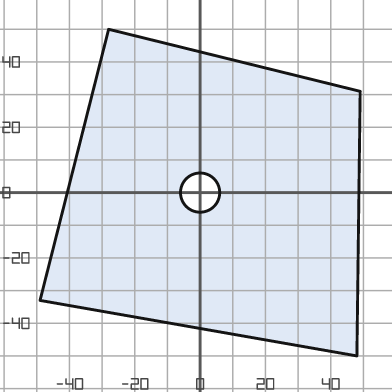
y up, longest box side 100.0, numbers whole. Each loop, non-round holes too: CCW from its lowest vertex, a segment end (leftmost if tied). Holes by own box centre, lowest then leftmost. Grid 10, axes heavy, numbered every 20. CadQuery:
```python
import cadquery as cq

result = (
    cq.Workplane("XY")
    .moveTo(48.0, -50.0)
    .lineTo(49.0, 31.0)
    .lineTo(-28.0, 50.0)
    .lineTo(-49.0, -33.0)
    .close()
    .moveTo(0.0, 0.0)
    .circle(6.0)
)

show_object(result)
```